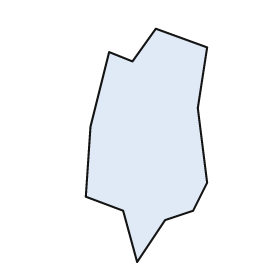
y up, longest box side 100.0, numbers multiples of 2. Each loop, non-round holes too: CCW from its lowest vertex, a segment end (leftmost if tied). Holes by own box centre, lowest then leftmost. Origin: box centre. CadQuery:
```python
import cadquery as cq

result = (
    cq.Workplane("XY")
    .moveTo(-4.0, -50.0)
    .lineTo(8.0, -32.0)
    .lineTo(20.0, -28.0)
    .lineTo(26.0, -16.0)
    .lineTo(22.0, 16.0)
    .lineTo(26.0, 42.0)
    .lineTo(4.0, 50.0)
    .lineTo(-6.0, 36.0)
    .lineTo(-16.0, 40.0)
    .lineTo(-24.0, 8.0)
    .lineTo(-26.0, -22.0)
    .lineTo(-10.0, -28.0)
    .close()
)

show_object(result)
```